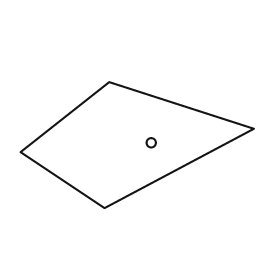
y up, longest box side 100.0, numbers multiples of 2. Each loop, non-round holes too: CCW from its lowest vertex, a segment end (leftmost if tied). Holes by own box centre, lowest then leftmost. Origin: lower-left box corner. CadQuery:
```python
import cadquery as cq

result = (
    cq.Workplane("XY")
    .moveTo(36.0, 0.0)
    .lineTo(100.0, 34.0)
    .lineTo(38.0, 54.0)
    .lineTo(0.0, 24.0)
    .close()
    .moveTo(56.0, 28.0)
    .circle(2.0)
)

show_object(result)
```